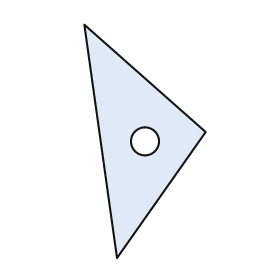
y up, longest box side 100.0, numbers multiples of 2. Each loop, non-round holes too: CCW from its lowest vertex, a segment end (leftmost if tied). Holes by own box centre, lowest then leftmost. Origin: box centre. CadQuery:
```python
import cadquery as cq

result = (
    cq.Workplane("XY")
    .moveTo(-12.0, -50.0)
    .lineTo(26.0, 4.0)
    .lineTo(-26.0, 50.0)
    .close()
    .moveTo(0.0, 0.0)
    .circle(6.0)
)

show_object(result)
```